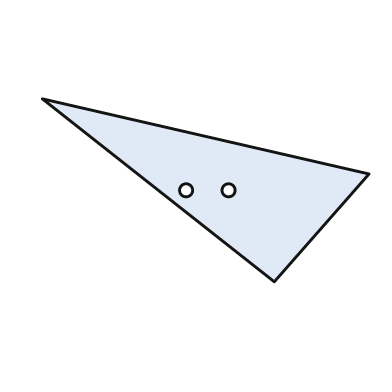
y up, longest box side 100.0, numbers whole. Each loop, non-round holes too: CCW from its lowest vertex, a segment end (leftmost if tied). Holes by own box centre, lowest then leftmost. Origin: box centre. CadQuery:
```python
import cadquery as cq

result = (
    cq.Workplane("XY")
    .moveTo(21.0, -28.0)
    .lineTo(50.0, 5.0)
    .lineTo(-50.0, 28.0)
    .close()
    .moveTo(-6.0, 0.0)
    .circle(2.0)
    .moveTo(7.0, 0.0)
    .circle(2.0)
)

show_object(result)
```